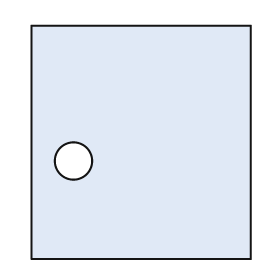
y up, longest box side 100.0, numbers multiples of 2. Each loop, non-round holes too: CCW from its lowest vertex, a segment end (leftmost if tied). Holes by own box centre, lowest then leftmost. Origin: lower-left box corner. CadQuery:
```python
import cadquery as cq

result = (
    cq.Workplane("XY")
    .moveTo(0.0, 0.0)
    .lineTo(94.0, 0.0)
    .lineTo(94.0, 100.0)
    .lineTo(0.0, 100.0)
    .close()
    .moveTo(18.0, 42.0)
    .circle(8.0)
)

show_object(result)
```